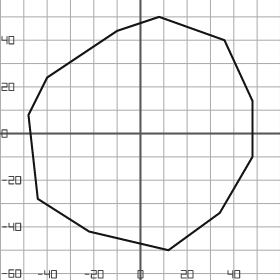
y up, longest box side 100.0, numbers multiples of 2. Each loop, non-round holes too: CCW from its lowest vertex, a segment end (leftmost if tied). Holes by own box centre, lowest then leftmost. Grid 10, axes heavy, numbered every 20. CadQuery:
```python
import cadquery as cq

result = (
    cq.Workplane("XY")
    .moveTo(12.0, -50.0)
    .lineTo(34.0, -34.0)
    .lineTo(48.0, -10.0)
    .lineTo(48.0, 14.0)
    .lineTo(36.0, 40.0)
    .lineTo(8.0, 50.0)
    .lineTo(-10.0, 44.0)
    .lineTo(-40.0, 24.0)
    .lineTo(-48.0, 8.0)
    .lineTo(-44.0, -28.0)
    .lineTo(-22.0, -42.0)
    .close()
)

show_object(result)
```